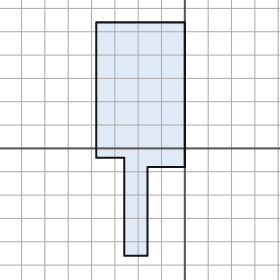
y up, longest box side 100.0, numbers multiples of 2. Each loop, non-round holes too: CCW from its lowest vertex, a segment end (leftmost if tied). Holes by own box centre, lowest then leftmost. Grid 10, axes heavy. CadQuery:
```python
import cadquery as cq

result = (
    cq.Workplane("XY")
    .moveTo(-26.0, -46.0)
    .lineTo(-16.0, -46.0)
    .lineTo(-16.0, -8.0)
    .lineTo(0.0, -8.0)
    .lineTo(0.0, 54.0)
    .lineTo(-38.0, 54.0)
    .lineTo(-38.0, -4.0)
    .lineTo(-26.0, -4.0)
    .close()
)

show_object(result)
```